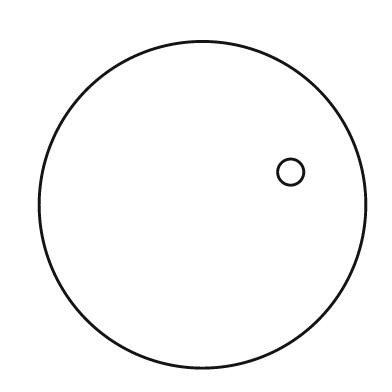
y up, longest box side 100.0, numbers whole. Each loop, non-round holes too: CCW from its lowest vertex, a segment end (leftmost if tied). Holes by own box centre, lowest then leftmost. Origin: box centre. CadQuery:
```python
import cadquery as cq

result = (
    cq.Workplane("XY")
    .moveTo(0.0, 0.0)
    .circle(50.0)
    .moveTo(27.0, 10.0)
    .circle(4.0)
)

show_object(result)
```